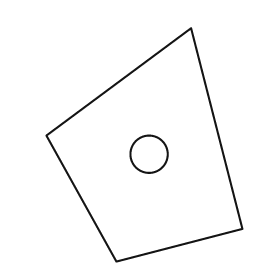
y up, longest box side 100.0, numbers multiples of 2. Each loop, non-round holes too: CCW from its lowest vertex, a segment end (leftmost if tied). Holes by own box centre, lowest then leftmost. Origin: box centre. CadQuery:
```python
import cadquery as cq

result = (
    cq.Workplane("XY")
    .moveTo(-12.0, -50.0)
    .lineTo(42.0, -36.0)
    .lineTo(20.0, 50.0)
    .lineTo(-42.0, 4.0)
    .close()
    .moveTo(2.0, -4.0)
    .circle(8.0)
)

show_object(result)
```